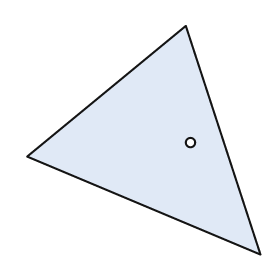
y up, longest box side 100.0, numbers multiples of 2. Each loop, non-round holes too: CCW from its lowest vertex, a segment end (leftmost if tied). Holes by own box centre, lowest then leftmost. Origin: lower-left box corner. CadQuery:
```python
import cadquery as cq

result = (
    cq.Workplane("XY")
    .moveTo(100.0, 0.0)
    .lineTo(68.0, 98.0)
    .lineTo(0.0, 42.0)
    .close()
    .moveTo(70.0, 48.0)
    .circle(2.0)
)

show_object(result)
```